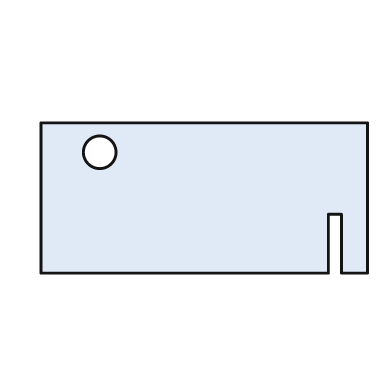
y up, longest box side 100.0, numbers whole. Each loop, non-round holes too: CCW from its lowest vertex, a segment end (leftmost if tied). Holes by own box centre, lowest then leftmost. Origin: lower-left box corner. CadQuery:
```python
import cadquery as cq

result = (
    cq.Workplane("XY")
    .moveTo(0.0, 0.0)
    .lineTo(88.0, 0.0)
    .lineTo(88.0, 18.0)
    .lineTo(92.0, 18.0)
    .lineTo(92.0, 0.0)
    .lineTo(100.0, 0.0)
    .lineTo(100.0, 46.0)
    .lineTo(0.0, 46.0)
    .close()
    .moveTo(18.0, 37.0)
    .circle(5.0)
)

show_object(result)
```